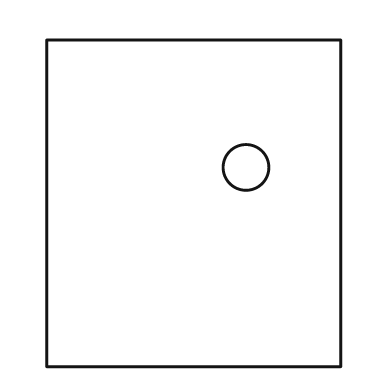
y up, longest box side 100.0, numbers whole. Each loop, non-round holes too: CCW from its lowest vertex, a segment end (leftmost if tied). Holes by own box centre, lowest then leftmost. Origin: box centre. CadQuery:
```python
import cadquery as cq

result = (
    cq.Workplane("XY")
    .moveTo(-45.0, -50.0)
    .lineTo(45.0, -50.0)
    .lineTo(45.0, 50.0)
    .lineTo(-45.0, 50.0)
    .close()
    .moveTo(16.0, 11.0)
    .circle(7.0)
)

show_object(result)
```